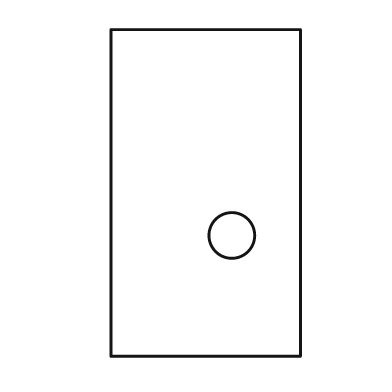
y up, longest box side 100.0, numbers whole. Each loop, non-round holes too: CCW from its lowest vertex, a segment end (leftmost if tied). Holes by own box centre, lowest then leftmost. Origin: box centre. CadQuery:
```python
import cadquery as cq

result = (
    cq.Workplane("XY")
    .moveTo(-29.0, -50.0)
    .lineTo(29.0, -50.0)
    .lineTo(29.0, 50.0)
    .lineTo(-29.0, 50.0)
    .close()
    .moveTo(8.0, -13.0)
    .circle(7.0)
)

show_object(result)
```